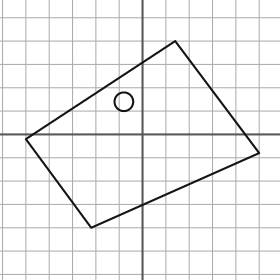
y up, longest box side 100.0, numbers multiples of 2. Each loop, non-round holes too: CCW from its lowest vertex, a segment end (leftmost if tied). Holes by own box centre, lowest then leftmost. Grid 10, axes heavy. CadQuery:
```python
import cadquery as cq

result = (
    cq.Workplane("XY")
    .moveTo(-22.0, -40.0)
    .lineTo(50.0, -8.0)
    .lineTo(14.0, 40.0)
    .lineTo(-50.0, -2.0)
    .close()
    .moveTo(-8.0, 14.0)
    .circle(4.0)
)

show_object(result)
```